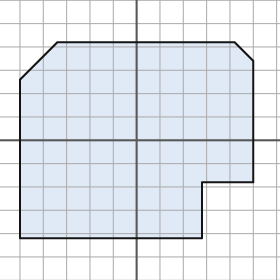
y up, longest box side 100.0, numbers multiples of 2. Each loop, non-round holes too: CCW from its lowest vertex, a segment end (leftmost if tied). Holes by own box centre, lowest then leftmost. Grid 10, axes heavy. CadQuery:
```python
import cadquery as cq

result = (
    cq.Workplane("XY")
    .moveTo(-50.0, -42.0)
    .lineTo(28.0, -42.0)
    .lineTo(28.0, -18.0)
    .lineTo(50.0, -18.0)
    .lineTo(50.0, 34.0)
    .lineTo(42.0, 42.0)
    .lineTo(-34.0, 42.0)
    .lineTo(-50.0, 26.0)
    .close()
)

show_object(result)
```